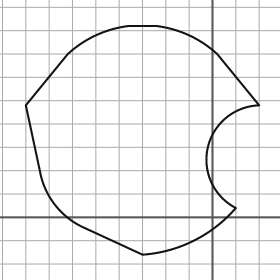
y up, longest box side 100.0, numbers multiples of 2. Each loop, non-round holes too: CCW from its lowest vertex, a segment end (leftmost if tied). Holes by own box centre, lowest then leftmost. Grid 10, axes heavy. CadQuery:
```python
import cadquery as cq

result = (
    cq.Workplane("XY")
    .moveTo(-30.0, -16.0)
    .threePointArc((-8.0, -10.0), (10.0, 4.0))
    .threePointArc((-2.0, 30.0), (20.0, 48.0))
    .lineTo(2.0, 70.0)
    .threePointArc((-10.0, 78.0), (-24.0, 82.0))
    .lineTo(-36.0, 82.0)
    .threePointArc((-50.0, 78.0), (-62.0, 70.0))
    .lineTo(-80.0, 48.0)
    .lineTo(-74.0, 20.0)
    .threePointArc((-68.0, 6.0), (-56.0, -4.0))
    .close()
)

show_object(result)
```